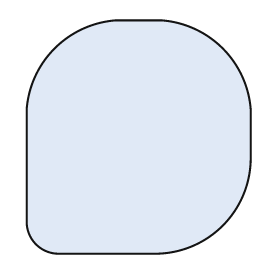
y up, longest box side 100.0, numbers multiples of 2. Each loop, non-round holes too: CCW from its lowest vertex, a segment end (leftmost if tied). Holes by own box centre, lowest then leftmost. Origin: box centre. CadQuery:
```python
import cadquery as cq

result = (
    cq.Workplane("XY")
    .moveTo(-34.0, -50.0)
    .lineTo(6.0, -50.0)
    .threePointArc((36.0, -38.0), (48.0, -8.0))
    .lineTo(48.0, 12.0)
    .threePointArc((36.0, 38.0), (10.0, 50.0))
    .lineTo(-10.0, 50.0)
    .threePointArc((-36.0, 38.0), (-48.0, 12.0))
    .lineTo(-48.0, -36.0)
    .threePointArc((-44.0, -46.0), (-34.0, -50.0))
    .close()
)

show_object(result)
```